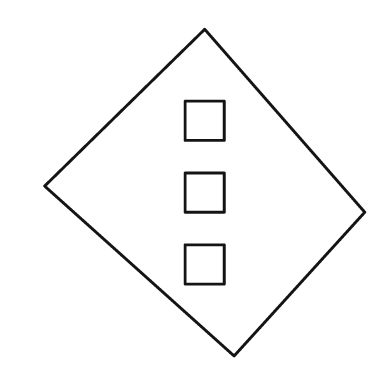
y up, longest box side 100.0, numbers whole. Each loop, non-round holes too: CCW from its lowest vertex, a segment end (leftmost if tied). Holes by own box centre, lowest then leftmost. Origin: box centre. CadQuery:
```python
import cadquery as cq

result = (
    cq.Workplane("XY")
    .moveTo(9.0, -50.0)
    .lineTo(49.0, -6.0)
    .lineTo(0.0, 50.0)
    .lineTo(-49.0, 2.0)
    .close()
    .moveTo(-6.0, -28.0)
    .lineTo(6.0, -28.0)
    .lineTo(6.0, -16.0)
    .lineTo(-6.0, -16.0)
    .close()
    .moveTo(-6.0, -6.0)
    .lineTo(6.0, -6.0)
    .lineTo(6.0, 6.0)
    .lineTo(-6.0, 6.0)
    .close()
    .moveTo(-6.0, 16.0)
    .lineTo(6.0, 16.0)
    .lineTo(6.0, 28.0)
    .lineTo(-6.0, 28.0)
    .close()
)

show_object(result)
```